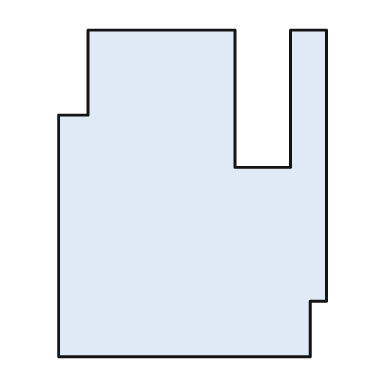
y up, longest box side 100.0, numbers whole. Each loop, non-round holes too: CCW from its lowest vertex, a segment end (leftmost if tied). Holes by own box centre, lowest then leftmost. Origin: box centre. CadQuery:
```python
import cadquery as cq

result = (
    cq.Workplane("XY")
    .moveTo(-41.0, -50.0)
    .lineTo(36.0, -50.0)
    .lineTo(36.0, -33.0)
    .lineTo(41.0, -33.0)
    .lineTo(41.0, 50.0)
    .lineTo(30.0, 50.0)
    .lineTo(30.0, 8.0)
    .lineTo(13.0, 8.0)
    .lineTo(13.0, 50.0)
    .lineTo(-32.0, 50.0)
    .lineTo(-32.0, 24.0)
    .lineTo(-41.0, 24.0)
    .close()
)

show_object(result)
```